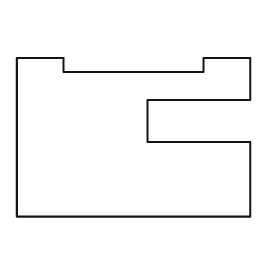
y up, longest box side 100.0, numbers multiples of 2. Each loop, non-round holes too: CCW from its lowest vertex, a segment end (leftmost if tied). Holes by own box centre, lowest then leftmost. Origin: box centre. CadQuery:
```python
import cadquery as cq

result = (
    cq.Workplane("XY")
    .moveTo(-50.0, -34.0)
    .lineTo(50.0, -34.0)
    .lineTo(50.0, -2.0)
    .lineTo(6.0, -2.0)
    .lineTo(6.0, 16.0)
    .lineTo(50.0, 16.0)
    .lineTo(50.0, 34.0)
    .lineTo(30.0, 34.0)
    .lineTo(30.0, 28.0)
    .lineTo(-30.0, 28.0)
    .lineTo(-30.0, 34.0)
    .lineTo(-50.0, 34.0)
    .close()
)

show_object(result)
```